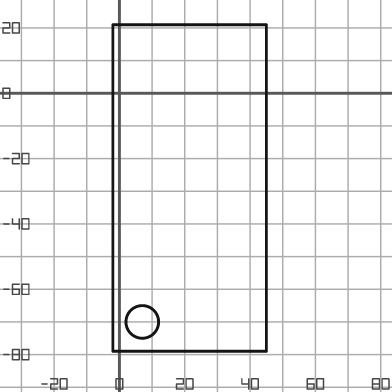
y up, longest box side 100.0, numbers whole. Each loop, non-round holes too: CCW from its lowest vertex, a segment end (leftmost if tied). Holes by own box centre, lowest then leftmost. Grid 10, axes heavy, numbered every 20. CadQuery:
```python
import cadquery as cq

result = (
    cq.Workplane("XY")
    .moveTo(-2.0, -79.0)
    .lineTo(45.0, -79.0)
    .lineTo(45.0, 21.0)
    .lineTo(-2.0, 21.0)
    .close()
    .moveTo(7.0, -70.0)
    .circle(5.0)
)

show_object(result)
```